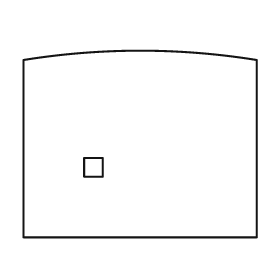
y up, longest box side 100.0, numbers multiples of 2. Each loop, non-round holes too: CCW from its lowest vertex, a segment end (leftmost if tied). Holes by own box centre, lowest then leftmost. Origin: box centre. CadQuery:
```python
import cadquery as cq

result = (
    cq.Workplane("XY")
    .moveTo(-50.0, -40.0)
    .lineTo(50.0, -40.0)
    .lineTo(50.0, 36.0)
    .threePointArc((0.0, 40.0), (-50.0, 36.0))
    .close()
    .moveTo(-24.0, -14.0)
    .lineTo(-16.0, -14.0)
    .lineTo(-16.0, -6.0)
    .lineTo(-24.0, -6.0)
    .close()
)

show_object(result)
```